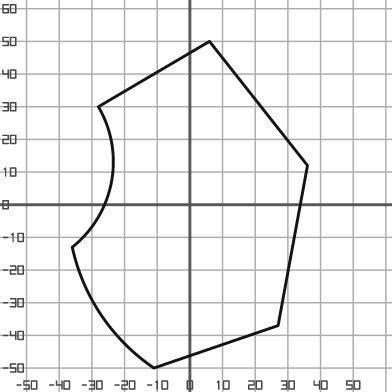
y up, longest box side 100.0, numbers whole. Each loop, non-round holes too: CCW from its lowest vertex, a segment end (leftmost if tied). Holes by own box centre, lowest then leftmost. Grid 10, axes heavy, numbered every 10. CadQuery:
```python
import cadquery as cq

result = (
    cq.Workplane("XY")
    .moveTo(-11.0, -50.0)
    .lineTo(27.0, -37.0)
    .lineTo(36.0, 12.0)
    .lineTo(6.0, 50.0)
    .lineTo(-28.0, 30.0)
    .threePointArc((-24.0, 7.0), (-36.0, -13.0))
    .threePointArc((-27.0, -34.0), (-11.0, -50.0))
    .close()
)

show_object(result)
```